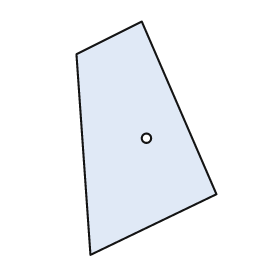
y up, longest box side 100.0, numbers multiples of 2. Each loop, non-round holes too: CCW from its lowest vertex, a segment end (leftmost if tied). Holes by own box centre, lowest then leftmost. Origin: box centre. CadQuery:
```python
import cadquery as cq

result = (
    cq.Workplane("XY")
    .moveTo(-24.0, -50.0)
    .lineTo(30.0, -24.0)
    .lineTo(-2.0, 50.0)
    .lineTo(-30.0, 36.0)
    .close()
    .moveTo(0.0, 0.0)
    .circle(2.0)
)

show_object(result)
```